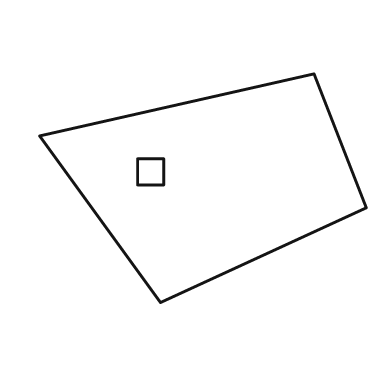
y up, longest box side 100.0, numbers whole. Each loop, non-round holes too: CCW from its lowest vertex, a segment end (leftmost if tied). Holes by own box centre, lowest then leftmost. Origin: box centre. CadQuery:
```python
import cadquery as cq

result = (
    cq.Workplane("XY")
    .moveTo(-13.0, -35.0)
    .lineTo(50.0, -6.0)
    .lineTo(34.0, 35.0)
    .lineTo(-50.0, 16.0)
    .close()
    .moveTo(-20.0, 1.0)
    .lineTo(-12.0, 1.0)
    .lineTo(-12.0, 9.0)
    .lineTo(-20.0, 9.0)
    .close()
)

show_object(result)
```